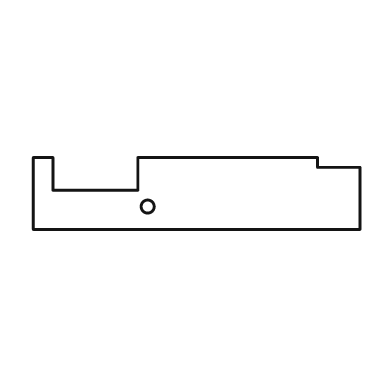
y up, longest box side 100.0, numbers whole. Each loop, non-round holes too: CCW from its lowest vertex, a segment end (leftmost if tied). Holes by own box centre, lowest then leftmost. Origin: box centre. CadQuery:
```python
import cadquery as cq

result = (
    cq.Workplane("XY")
    .moveTo(-50.0, -11.0)
    .lineTo(50.0, -11.0)
    .lineTo(50.0, 8.0)
    .lineTo(37.0, 8.0)
    .lineTo(37.0, 11.0)
    .lineTo(-18.0, 11.0)
    .lineTo(-18.0, 1.0)
    .lineTo(-44.0, 1.0)
    .lineTo(-44.0, 11.0)
    .lineTo(-50.0, 11.0)
    .close()
    .moveTo(-15.0, -4.0)
    .circle(2.0)
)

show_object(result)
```